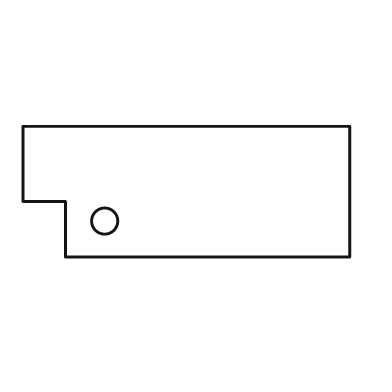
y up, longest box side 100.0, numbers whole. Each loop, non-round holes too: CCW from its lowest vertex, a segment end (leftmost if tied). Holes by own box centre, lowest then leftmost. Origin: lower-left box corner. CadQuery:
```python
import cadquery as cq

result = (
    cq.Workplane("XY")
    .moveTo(13.0, 0.0)
    .lineTo(100.0, 0.0)
    .lineTo(100.0, 40.0)
    .lineTo(0.0, 40.0)
    .lineTo(0.0, 17.0)
    .lineTo(13.0, 17.0)
    .close()
    .moveTo(25.0, 11.0)
    .circle(4.0)
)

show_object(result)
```